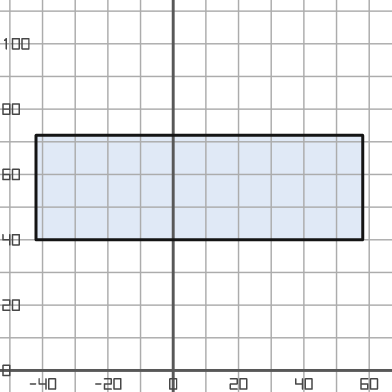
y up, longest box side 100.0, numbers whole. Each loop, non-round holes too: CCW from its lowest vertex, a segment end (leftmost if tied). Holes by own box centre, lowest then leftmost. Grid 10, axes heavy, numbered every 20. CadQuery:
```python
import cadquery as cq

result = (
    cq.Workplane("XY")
    .moveTo(-42.0, 40.0)
    .lineTo(58.0, 40.0)
    .lineTo(58.0, 72.0)
    .lineTo(-42.0, 72.0)
    .close()
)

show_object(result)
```